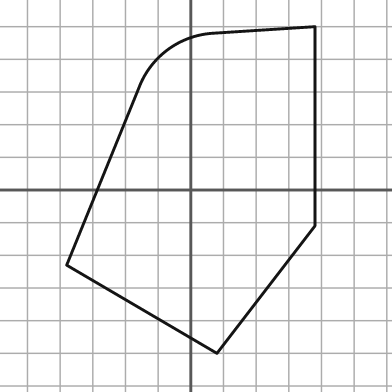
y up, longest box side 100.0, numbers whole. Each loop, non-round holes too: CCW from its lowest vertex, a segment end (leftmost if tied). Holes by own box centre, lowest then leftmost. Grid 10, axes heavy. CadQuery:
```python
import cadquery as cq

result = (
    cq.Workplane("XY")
    .moveTo(8.0, -50.0)
    .lineTo(38.0, -11.0)
    .lineTo(38.0, 50.0)
    .lineTo(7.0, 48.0)
    .threePointArc((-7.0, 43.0), (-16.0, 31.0))
    .lineTo(-38.0, -23.0)
    .close()
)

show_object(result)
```